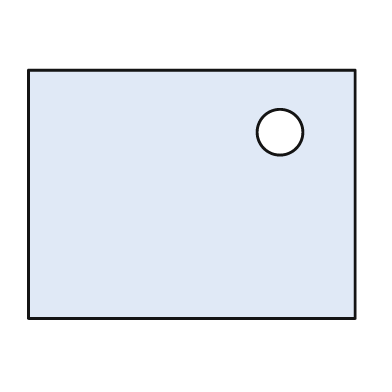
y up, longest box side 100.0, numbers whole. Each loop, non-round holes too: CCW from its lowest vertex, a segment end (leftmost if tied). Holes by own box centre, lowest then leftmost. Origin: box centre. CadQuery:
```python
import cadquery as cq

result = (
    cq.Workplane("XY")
    .moveTo(-50.0, -38.0)
    .lineTo(50.0, -38.0)
    .lineTo(50.0, 38.0)
    .lineTo(-50.0, 38.0)
    .close()
    .moveTo(27.0, 19.0)
    .circle(7.0)
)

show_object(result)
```